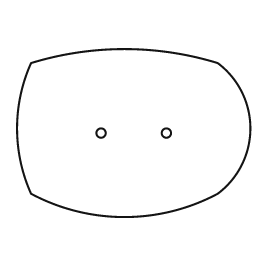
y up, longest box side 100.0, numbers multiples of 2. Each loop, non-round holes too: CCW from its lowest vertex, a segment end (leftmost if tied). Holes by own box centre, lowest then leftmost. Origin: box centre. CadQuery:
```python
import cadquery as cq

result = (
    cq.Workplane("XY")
    .moveTo(-44.0, -26.0)
    .threePointArc((-4.0, -36.0), (36.0, -26.0))
    .threePointArc((50.0, 2.0), (36.0, 30.0))
    .threePointArc((-4.0, 36.0), (-44.0, 30.0))
    .threePointArc((-50.0, 2.0), (-44.0, -26.0))
    .close()
    .moveTo(-14.0, 0.0)
    .circle(2.0)
    .moveTo(14.0, 0.0)
    .circle(2.0)
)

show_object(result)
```